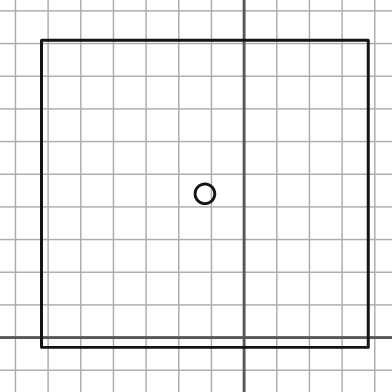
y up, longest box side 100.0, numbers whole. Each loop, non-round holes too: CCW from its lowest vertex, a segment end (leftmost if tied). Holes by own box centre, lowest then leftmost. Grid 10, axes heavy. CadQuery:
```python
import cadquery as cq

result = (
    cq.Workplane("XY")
    .moveTo(-62.0, -3.0)
    .lineTo(38.0, -3.0)
    .lineTo(38.0, 91.0)
    .lineTo(-62.0, 91.0)
    .close()
    .moveTo(-12.0, 44.0)
    .circle(3.0)
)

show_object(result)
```